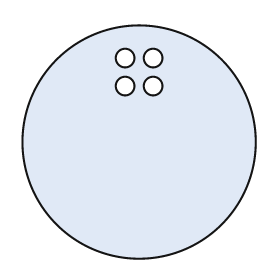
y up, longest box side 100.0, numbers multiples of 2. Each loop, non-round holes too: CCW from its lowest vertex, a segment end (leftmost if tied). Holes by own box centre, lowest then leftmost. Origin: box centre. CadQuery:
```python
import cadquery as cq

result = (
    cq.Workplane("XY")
    .moveTo(0.0, 0.0)
    .circle(50.0)
    .moveTo(-6.0, 24.0)
    .circle(4.0)
    .moveTo(6.0, 24.0)
    .circle(4.0)
    .moveTo(-6.0, 36.0)
    .circle(4.0)
    .moveTo(6.0, 36.0)
    .circle(4.0)
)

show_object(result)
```